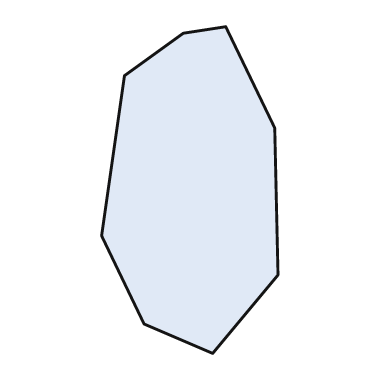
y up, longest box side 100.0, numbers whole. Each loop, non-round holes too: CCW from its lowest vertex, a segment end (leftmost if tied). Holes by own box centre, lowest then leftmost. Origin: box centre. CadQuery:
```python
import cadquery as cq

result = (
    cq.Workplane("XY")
    .moveTo(7.0, -50.0)
    .lineTo(27.0, -26.0)
    .lineTo(26.0, 19.0)
    .lineTo(11.0, 50.0)
    .lineTo(-2.0, 48.0)
    .lineTo(-20.0, 35.0)
    .lineTo(-27.0, -14.0)
    .lineTo(-14.0, -41.0)
    .close()
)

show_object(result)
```